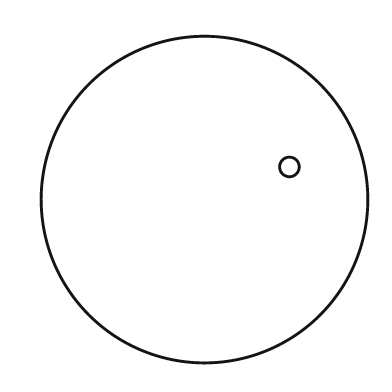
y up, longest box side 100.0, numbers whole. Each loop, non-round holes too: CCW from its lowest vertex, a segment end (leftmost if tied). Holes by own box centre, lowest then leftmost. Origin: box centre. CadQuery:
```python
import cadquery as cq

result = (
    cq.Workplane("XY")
    .moveTo(0.0, 0.0)
    .circle(50.0)
    .moveTo(26.0, 10.0)
    .circle(3.0)
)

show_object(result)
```